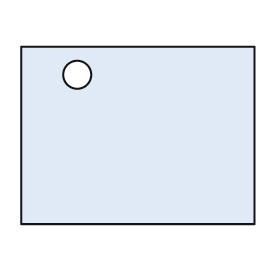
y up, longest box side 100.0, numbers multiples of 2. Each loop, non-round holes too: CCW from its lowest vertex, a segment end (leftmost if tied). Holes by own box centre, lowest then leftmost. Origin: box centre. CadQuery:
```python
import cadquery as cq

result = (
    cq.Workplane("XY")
    .moveTo(-50.0, -38.0)
    .lineTo(50.0, -38.0)
    .lineTo(50.0, 38.0)
    .lineTo(-50.0, 38.0)
    .close()
    .moveTo(-26.0, 26.0)
    .circle(6.0)
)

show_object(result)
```